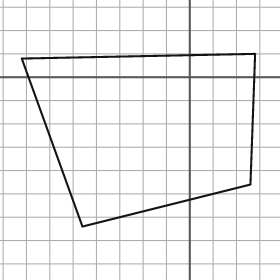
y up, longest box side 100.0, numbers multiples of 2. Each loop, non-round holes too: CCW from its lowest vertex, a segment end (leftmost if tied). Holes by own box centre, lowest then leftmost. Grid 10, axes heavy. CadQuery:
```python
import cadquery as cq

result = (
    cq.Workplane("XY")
    .moveTo(-46.0, -64.0)
    .lineTo(26.0, -46.0)
    .lineTo(28.0, 10.0)
    .lineTo(-72.0, 8.0)
    .close()
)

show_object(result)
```